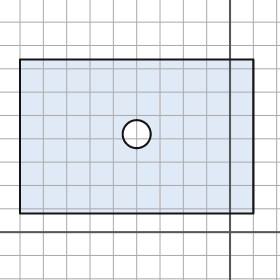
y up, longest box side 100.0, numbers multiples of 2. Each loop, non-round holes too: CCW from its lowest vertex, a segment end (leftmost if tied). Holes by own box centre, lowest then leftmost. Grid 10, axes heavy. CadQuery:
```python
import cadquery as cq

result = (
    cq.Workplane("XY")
    .moveTo(-90.0, 8.0)
    .lineTo(10.0, 8.0)
    .lineTo(10.0, 74.0)
    .lineTo(-90.0, 74.0)
    .close()
    .moveTo(-40.0, 42.0)
    .circle(6.0)
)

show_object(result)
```